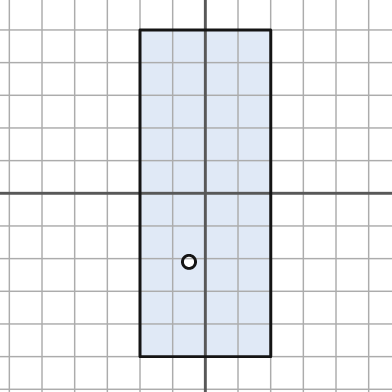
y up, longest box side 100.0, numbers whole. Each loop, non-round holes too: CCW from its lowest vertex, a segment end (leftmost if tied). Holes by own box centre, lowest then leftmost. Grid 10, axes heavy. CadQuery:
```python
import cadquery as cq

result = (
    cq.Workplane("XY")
    .moveTo(-20.0, -50.0)
    .lineTo(20.0, -50.0)
    .lineTo(20.0, 50.0)
    .lineTo(-20.0, 50.0)
    .close()
    .moveTo(-5.0, -21.0)
    .circle(2.0)
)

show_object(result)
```